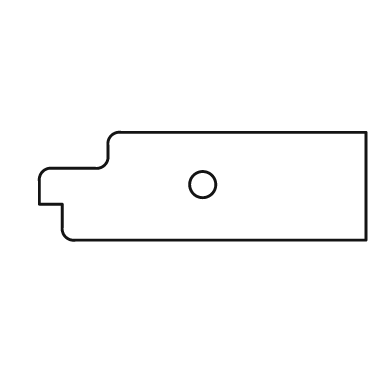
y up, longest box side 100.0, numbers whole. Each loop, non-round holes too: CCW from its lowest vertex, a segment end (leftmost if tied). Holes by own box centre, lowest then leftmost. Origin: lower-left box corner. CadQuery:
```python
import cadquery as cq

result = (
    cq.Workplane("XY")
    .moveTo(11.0, 0.0)
    .lineTo(100.0, 0.0)
    .lineTo(100.0, 33.0)
    .lineTo(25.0, 33.0)
    .threePointArc((22.0, 32.0), (21.0, 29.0))
    .lineTo(21.0, 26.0)
    .threePointArc((20.0, 23.0), (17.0, 22.0))
    .lineTo(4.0, 22.0)
    .threePointArc((1.0, 21.0), (0.0, 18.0))
    .lineTo(0.0, 11.0)
    .lineTo(7.0, 11.0)
    .lineTo(7.0, 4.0)
    .threePointArc((8.0, 1.0), (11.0, 0.0))
    .close()
    .moveTo(50.0, 17.0)
    .circle(4.0)
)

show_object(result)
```